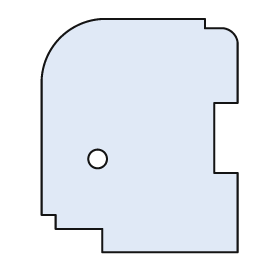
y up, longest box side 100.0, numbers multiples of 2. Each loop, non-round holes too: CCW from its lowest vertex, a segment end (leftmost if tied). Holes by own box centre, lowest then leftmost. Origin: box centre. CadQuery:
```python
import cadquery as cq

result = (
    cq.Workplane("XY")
    .moveTo(-16.0, -50.0)
    .lineTo(42.0, -50.0)
    .lineTo(42.0, -16.0)
    .lineTo(32.0, -16.0)
    .lineTo(32.0, 14.0)
    .lineTo(42.0, 14.0)
    .lineTo(42.0, 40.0)
    .threePointArc((40.0, 44.0), (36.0, 46.0))
    .lineTo(28.0, 46.0)
    .lineTo(28.0, 50.0)
    .lineTo(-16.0, 50.0)
    .threePointArc((-34.0, 42.0), (-42.0, 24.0))
    .lineTo(-42.0, -34.0)
    .lineTo(-36.0, -34.0)
    .lineTo(-36.0, -40.0)
    .lineTo(-16.0, -40.0)
    .close()
    .moveTo(-18.0, -10.0)
    .circle(4.0)
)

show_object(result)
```